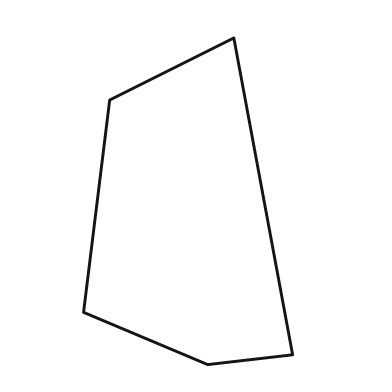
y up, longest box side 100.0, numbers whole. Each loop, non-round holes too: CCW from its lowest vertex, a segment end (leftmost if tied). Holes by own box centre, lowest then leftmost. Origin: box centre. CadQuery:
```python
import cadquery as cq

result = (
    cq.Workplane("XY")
    .moveTo(6.0, -50.0)
    .lineTo(32.0, -47.0)
    .lineTo(14.0, 50.0)
    .lineTo(-24.0, 31.0)
    .lineTo(-32.0, -34.0)
    .close()
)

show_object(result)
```